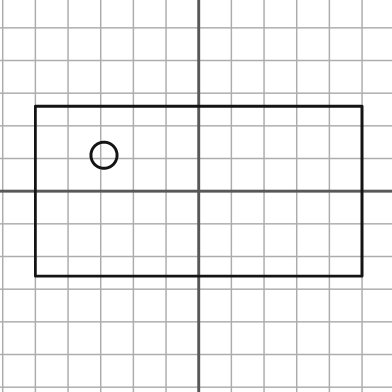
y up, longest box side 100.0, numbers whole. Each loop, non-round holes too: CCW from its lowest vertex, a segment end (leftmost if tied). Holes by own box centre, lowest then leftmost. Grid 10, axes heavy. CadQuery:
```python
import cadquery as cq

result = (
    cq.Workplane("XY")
    .moveTo(-50.0, -26.0)
    .lineTo(50.0, -26.0)
    .lineTo(50.0, 26.0)
    .lineTo(-50.0, 26.0)
    .close()
    .moveTo(-29.0, 11.0)
    .circle(4.0)
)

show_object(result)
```